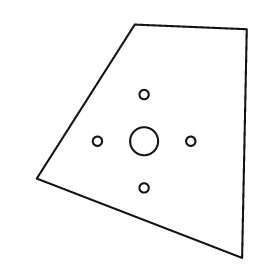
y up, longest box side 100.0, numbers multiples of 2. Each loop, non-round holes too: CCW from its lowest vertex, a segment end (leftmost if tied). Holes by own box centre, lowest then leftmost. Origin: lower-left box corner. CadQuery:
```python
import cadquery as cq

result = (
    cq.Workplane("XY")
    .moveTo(88.0, 0.0)
    .lineTo(90.0, 98.0)
    .lineTo(42.0, 100.0)
    .lineTo(0.0, 34.0)
    .close()
    .moveTo(46.0, 30.0)
    .circle(2.0)
    .moveTo(26.0, 50.0)
    .circle(2.0)
    .moveTo(46.0, 50.0)
    .circle(6.0)
    .moveTo(66.0, 50.0)
    .circle(2.0)
    .moveTo(46.0, 70.0)
    .circle(2.0)
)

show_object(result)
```